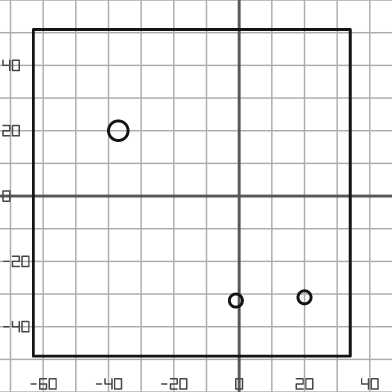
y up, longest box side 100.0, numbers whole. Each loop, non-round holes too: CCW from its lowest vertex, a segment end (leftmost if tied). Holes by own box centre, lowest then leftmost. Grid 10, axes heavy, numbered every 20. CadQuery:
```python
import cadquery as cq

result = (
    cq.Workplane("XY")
    .moveTo(-63.0, -49.0)
    .lineTo(34.0, -49.0)
    .lineTo(34.0, 51.0)
    .lineTo(-63.0, 51.0)
    .close()
    .moveTo(-1.0, -32.0)
    .circle(2.0)
    .moveTo(20.0, -31.0)
    .circle(2.0)
    .moveTo(-37.0, 20.0)
    .circle(3.0)
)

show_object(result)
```